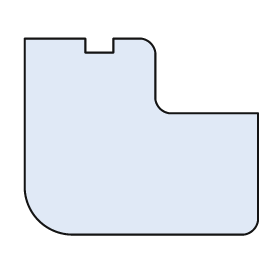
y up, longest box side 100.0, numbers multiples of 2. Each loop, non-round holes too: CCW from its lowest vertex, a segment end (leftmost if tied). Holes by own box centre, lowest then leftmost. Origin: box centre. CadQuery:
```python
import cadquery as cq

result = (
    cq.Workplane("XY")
    .moveTo(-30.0, -42.0)
    .lineTo(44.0, -42.0)
    .threePointArc((48.0, -40.0), (50.0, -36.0))
    .lineTo(50.0, 10.0)
    .lineTo(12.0, 10.0)
    .threePointArc((8.0, 12.0), (6.0, 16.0))
    .lineTo(6.0, 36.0)
    .threePointArc((4.0, 40.0), (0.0, 42.0))
    .lineTo(-12.0, 42.0)
    .lineTo(-12.0, 36.0)
    .lineTo(-24.0, 36.0)
    .lineTo(-24.0, 42.0)
    .lineTo(-50.0, 42.0)
    .lineTo(-50.0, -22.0)
    .threePointArc((-44.0, -36.0), (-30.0, -42.0))
    .close()
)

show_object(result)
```